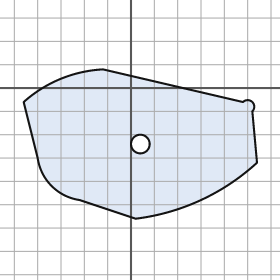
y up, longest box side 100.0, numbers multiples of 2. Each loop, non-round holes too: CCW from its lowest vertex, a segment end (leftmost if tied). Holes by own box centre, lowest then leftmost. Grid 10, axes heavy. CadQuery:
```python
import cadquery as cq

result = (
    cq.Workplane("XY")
    .moveTo(2.0, -56.0)
    .threePointArc((30.0, -48.0), (54.0, -32.0))
    .lineTo(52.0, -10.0)
    .threePointArc((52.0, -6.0), (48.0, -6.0))
    .lineTo(-12.0, 8.0)
    .threePointArc((-30.0, 4.0), (-46.0, -6.0))
    .lineTo(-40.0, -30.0)
    .threePointArc((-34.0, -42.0), (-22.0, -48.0))
    .close()
    .moveTo(4.0, -24.0)
    .circle(4.0)
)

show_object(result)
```